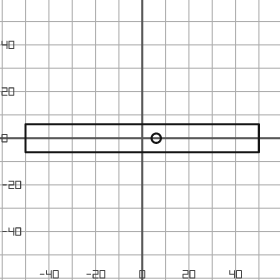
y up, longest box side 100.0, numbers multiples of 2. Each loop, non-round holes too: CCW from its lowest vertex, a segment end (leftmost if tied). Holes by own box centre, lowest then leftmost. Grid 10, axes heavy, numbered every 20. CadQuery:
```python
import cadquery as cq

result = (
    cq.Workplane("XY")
    .moveTo(-50.0, -6.0)
    .lineTo(50.0, -6.0)
    .lineTo(50.0, 6.0)
    .lineTo(-50.0, 6.0)
    .close()
    .moveTo(6.0, 0.0)
    .circle(2.0)
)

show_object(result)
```